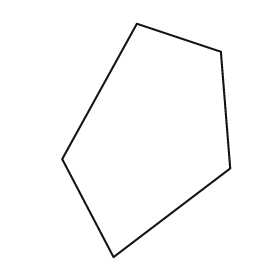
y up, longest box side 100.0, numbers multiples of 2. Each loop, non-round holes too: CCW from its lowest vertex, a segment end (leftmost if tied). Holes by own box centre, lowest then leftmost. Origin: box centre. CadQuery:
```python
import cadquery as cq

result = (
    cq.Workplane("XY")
    .moveTo(-14.0, -50.0)
    .lineTo(36.0, -12.0)
    .lineTo(32.0, 38.0)
    .lineTo(-4.0, 50.0)
    .lineTo(-36.0, -8.0)
    .close()
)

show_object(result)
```